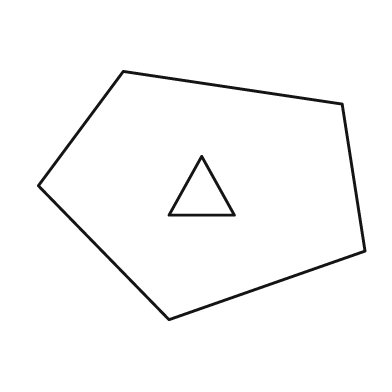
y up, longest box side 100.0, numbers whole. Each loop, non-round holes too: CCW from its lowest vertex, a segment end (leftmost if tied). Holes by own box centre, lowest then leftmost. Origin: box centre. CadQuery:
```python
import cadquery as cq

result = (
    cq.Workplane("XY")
    .moveTo(-10.0, -38.0)
    .lineTo(50.0, -17.0)
    .lineTo(43.0, 28.0)
    .lineTo(-24.0, 38.0)
    .lineTo(-50.0, 3.0)
    .close()
    .moveTo(-10.0, -6.0)
    .lineTo(10.0, -6.0)
    .lineTo(0.0, 12.0)
    .close()
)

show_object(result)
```